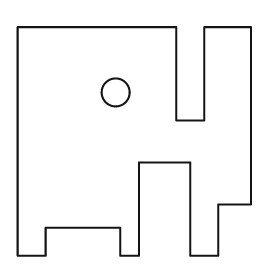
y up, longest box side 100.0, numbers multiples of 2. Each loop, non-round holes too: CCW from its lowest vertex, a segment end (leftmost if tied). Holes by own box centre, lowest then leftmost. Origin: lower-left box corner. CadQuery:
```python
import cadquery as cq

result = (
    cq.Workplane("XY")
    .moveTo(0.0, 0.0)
    .lineTo(12.0, 0.0)
    .lineTo(12.0, 12.0)
    .lineTo(44.0, 12.0)
    .lineTo(44.0, 0.0)
    .lineTo(52.0, 0.0)
    .lineTo(52.0, 40.0)
    .lineTo(74.0, 40.0)
    .lineTo(74.0, 0.0)
    .lineTo(86.0, 0.0)
    .lineTo(86.0, 22.0)
    .lineTo(100.0, 22.0)
    .lineTo(100.0, 98.0)
    .lineTo(80.0, 98.0)
    .lineTo(80.0, 58.0)
    .lineTo(68.0, 58.0)
    .lineTo(68.0, 98.0)
    .lineTo(0.0, 98.0)
    .close()
    .moveTo(42.0, 70.0)
    .circle(6.0)
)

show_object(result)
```